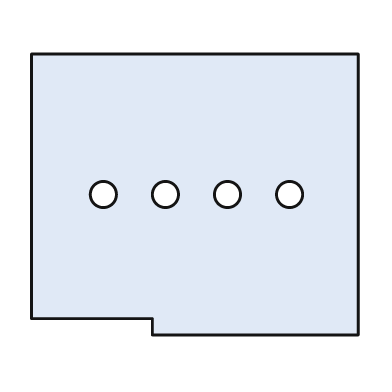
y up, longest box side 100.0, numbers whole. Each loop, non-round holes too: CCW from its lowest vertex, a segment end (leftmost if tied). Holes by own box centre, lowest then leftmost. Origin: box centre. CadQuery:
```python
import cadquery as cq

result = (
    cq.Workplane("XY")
    .moveTo(-13.0, -43.0)
    .lineTo(50.0, -43.0)
    .lineTo(50.0, 43.0)
    .lineTo(-50.0, 43.0)
    .lineTo(-50.0, -38.0)
    .lineTo(-13.0, -38.0)
    .close()
    .moveTo(-28.0, 0.0)
    .circle(4.0)
    .moveTo(-9.0, 0.0)
    .circle(4.0)
    .moveTo(10.0, 0.0)
    .circle(4.0)
    .moveTo(29.0, 0.0)
    .circle(4.0)
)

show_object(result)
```